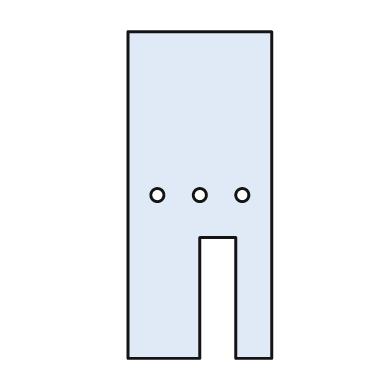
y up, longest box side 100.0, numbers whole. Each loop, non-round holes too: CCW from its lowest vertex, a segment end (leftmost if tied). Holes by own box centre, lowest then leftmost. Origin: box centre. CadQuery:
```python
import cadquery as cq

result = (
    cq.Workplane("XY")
    .moveTo(-22.0, -50.0)
    .lineTo(0.0, -50.0)
    .lineTo(0.0, -13.0)
    .lineTo(11.0, -13.0)
    .lineTo(11.0, -50.0)
    .lineTo(22.0, -50.0)
    .lineTo(22.0, 50.0)
    .lineTo(-22.0, 50.0)
    .close()
    .moveTo(-13.0, 0.0)
    .circle(2.0)
    .moveTo(0.0, 0.0)
    .circle(2.0)
    .moveTo(13.0, 0.0)
    .circle(2.0)
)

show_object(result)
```